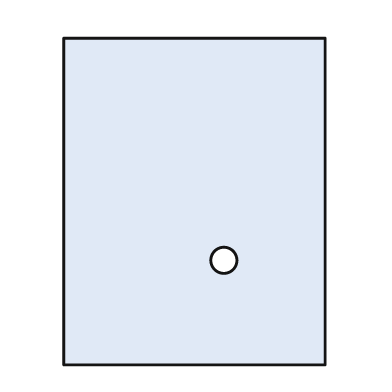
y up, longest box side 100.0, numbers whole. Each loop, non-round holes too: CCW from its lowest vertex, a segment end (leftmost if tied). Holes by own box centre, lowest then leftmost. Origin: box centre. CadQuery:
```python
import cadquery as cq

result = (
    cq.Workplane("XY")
    .moveTo(-40.0, -50.0)
    .lineTo(40.0, -50.0)
    .lineTo(40.0, 50.0)
    .lineTo(-40.0, 50.0)
    .close()
    .moveTo(9.0, -18.0)
    .circle(4.0)
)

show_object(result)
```